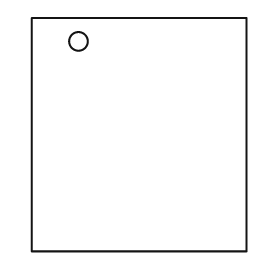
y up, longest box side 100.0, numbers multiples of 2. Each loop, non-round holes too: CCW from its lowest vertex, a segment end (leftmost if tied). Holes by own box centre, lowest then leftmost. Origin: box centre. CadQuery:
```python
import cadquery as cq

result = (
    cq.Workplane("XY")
    .moveTo(-46.0, -50.0)
    .lineTo(46.0, -50.0)
    .lineTo(46.0, 50.0)
    .lineTo(-46.0, 50.0)
    .close()
    .moveTo(-26.0, 40.0)
    .circle(4.0)
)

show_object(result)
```